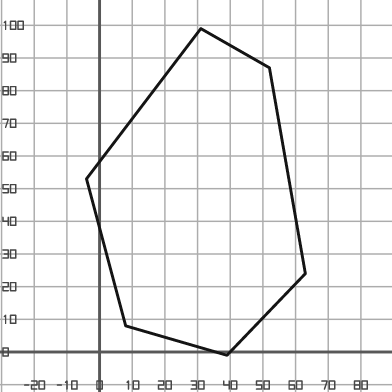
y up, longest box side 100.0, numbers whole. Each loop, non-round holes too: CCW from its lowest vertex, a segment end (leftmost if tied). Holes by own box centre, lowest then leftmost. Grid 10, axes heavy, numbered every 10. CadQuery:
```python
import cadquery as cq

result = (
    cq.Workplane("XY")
    .moveTo(39.0, -1.0)
    .lineTo(63.0, 24.0)
    .lineTo(52.0, 87.0)
    .lineTo(31.0, 99.0)
    .lineTo(-4.0, 53.0)
    .lineTo(8.0, 8.0)
    .close()
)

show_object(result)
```